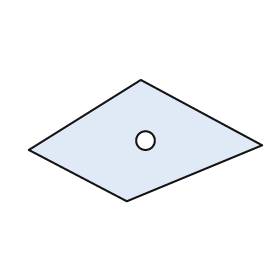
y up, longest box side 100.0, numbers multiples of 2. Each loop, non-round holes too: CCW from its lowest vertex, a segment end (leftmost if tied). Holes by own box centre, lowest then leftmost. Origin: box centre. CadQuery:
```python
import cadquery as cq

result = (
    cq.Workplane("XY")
    .moveTo(-8.0, -26.0)
    .lineTo(50.0, -2.0)
    .lineTo(-2.0, 26.0)
    .lineTo(-50.0, -4.0)
    .close()
    .moveTo(0.0, 0.0)
    .circle(4.0)
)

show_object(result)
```